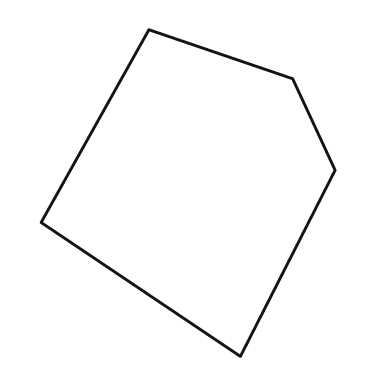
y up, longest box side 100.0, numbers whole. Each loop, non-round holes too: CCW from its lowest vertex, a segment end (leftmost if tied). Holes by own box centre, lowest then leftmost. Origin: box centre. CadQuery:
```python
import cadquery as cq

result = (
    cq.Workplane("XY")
    .moveTo(16.0, -50.0)
    .lineTo(45.0, 7.0)
    .lineTo(32.0, 35.0)
    .lineTo(-12.0, 50.0)
    .lineTo(-45.0, -9.0)
    .close()
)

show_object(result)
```